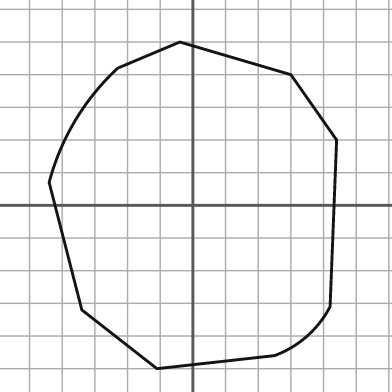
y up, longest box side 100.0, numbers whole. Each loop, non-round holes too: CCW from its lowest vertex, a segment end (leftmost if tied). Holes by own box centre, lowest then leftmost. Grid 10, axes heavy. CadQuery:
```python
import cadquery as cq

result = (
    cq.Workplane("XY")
    .moveTo(-11.0, -50.0)
    .lineTo(25.0, -46.0)
    .threePointArc((35.0, -40.0), (42.0, -31.0))
    .lineTo(44.0, 20.0)
    .lineTo(30.0, 40.0)
    .lineTo(-4.0, 50.0)
    .lineTo(-23.0, 42.0)
    .threePointArc((-36.0, 26.0), (-44.0, 7.0))
    .lineTo(-34.0, -32.0)
    .close()
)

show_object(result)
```